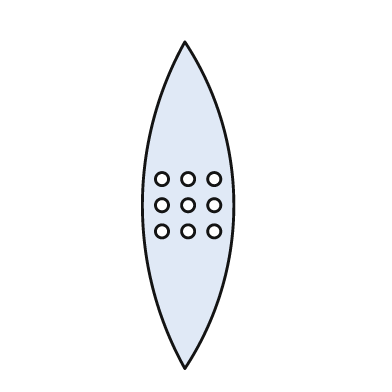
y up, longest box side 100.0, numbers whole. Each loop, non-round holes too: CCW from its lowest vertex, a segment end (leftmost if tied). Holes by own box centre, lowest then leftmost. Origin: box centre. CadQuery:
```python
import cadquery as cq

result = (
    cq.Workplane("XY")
    .moveTo(-1.0, -50.0)
    .threePointArc((14.0, 0.0), (-1.0, 50.0))
    .threePointArc((-14.0, 0.0), (-1.0, -50.0))
    .close()
    .moveTo(-8.0, -8.0)
    .circle(2.0)
    .moveTo(0.0, -8.0)
    .circle(2.0)
    .moveTo(8.0, -8.0)
    .circle(2.0)
    .moveTo(-8.0, 0.0)
    .circle(2.0)
    .moveTo(0.0, 0.0)
    .circle(2.0)
    .moveTo(8.0, 0.0)
    .circle(2.0)
    .moveTo(-8.0, 8.0)
    .circle(2.0)
    .moveTo(0.0, 8.0)
    .circle(2.0)
    .moveTo(8.0, 8.0)
    .circle(2.0)
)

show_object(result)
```